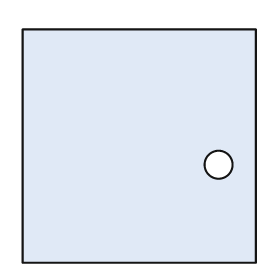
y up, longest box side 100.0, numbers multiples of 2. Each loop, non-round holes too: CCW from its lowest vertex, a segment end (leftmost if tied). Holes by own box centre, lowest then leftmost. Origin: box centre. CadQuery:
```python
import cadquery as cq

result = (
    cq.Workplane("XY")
    .moveTo(-50.0, -50.0)
    .lineTo(50.0, -50.0)
    .lineTo(50.0, 50.0)
    .lineTo(-50.0, 50.0)
    .close()
    .moveTo(34.0, -8.0)
    .circle(6.0)
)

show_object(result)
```